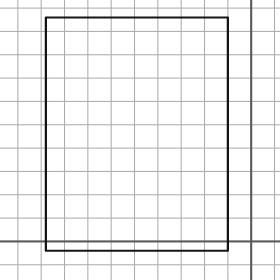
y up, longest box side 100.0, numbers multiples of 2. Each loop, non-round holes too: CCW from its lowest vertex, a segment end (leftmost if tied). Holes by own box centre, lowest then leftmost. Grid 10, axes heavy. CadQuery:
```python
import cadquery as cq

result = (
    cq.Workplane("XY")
    .moveTo(-88.0, -4.0)
    .lineTo(-10.0, -4.0)
    .lineTo(-10.0, 96.0)
    .lineTo(-88.0, 96.0)
    .close()
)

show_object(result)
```